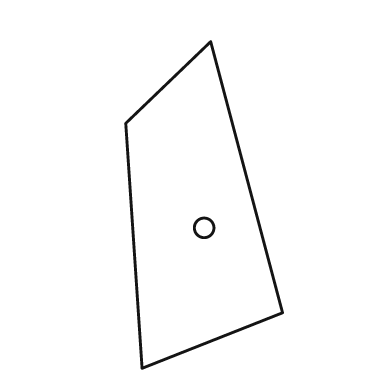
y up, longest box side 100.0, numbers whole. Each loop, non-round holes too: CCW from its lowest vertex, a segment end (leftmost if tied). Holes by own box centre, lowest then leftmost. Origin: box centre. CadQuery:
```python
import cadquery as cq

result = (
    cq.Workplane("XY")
    .moveTo(-19.0, -50.0)
    .lineTo(24.0, -33.0)
    .lineTo(2.0, 50.0)
    .lineTo(-24.0, 25.0)
    .close()
    .moveTo(0.0, -7.0)
    .circle(3.0)
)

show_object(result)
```